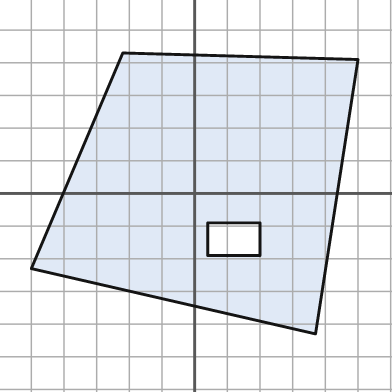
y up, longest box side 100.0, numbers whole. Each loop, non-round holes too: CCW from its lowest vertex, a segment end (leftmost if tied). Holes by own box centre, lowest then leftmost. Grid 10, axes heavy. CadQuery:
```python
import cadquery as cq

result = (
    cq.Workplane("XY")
    .moveTo(37.0, -43.0)
    .lineTo(50.0, 41.0)
    .lineTo(-22.0, 43.0)
    .lineTo(-50.0, -23.0)
    .close()
    .moveTo(4.0, -19.0)
    .lineTo(20.0, -19.0)
    .lineTo(20.0, -9.0)
    .lineTo(4.0, -9.0)
    .close()
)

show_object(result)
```